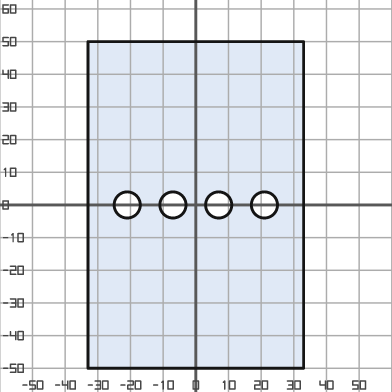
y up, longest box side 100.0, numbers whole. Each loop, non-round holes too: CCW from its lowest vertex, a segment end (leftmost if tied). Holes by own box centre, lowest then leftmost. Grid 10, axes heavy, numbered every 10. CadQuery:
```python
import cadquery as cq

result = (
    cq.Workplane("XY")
    .moveTo(-33.0, -50.0)
    .lineTo(33.0, -50.0)
    .lineTo(33.0, 50.0)
    .lineTo(-33.0, 50.0)
    .close()
    .moveTo(-21.0, 0.0)
    .circle(4.0)
    .moveTo(-7.0, 0.0)
    .circle(4.0)
    .moveTo(7.0, 0.0)
    .circle(4.0)
    .moveTo(21.0, 0.0)
    .circle(4.0)
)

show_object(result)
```